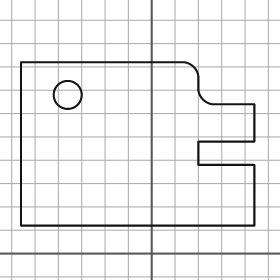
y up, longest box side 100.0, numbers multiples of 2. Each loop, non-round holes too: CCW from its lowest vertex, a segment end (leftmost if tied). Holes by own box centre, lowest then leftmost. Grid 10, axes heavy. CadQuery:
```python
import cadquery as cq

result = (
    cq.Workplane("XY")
    .moveTo(-56.0, 12.0)
    .lineTo(44.0, 12.0)
    .lineTo(44.0, 38.0)
    .lineTo(20.0, 38.0)
    .lineTo(20.0, 48.0)
    .lineTo(44.0, 48.0)
    .lineTo(44.0, 64.0)
    .lineTo(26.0, 64.0)
    .threePointArc((22.0, 66.0), (20.0, 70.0))
    .lineTo(20.0, 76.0)
    .threePointArc((18.0, 80.0), (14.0, 82.0))
    .lineTo(-56.0, 82.0)
    .close()
    .moveTo(-36.0, 68.0)
    .circle(6.0)
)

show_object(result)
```